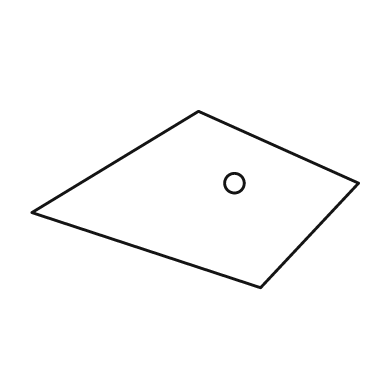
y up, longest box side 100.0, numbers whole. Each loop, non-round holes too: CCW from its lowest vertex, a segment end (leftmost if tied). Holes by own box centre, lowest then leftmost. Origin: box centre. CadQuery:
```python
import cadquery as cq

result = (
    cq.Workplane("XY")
    .moveTo(20.0, -27.0)
    .lineTo(50.0, 5.0)
    .lineTo(1.0, 27.0)
    .lineTo(-50.0, -4.0)
    .close()
    .moveTo(12.0, 5.0)
    .circle(3.0)
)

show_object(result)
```